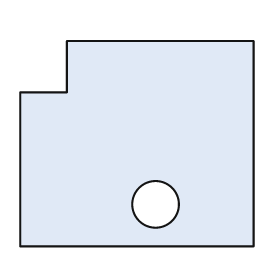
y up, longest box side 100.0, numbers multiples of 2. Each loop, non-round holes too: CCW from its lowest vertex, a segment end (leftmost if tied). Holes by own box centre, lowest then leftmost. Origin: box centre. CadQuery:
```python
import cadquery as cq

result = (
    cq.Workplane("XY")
    .moveTo(-50.0, -44.0)
    .lineTo(50.0, -44.0)
    .lineTo(50.0, 44.0)
    .lineTo(-30.0, 44.0)
    .lineTo(-30.0, 22.0)
    .lineTo(-50.0, 22.0)
    .close()
    .moveTo(8.0, -26.0)
    .circle(10.0)
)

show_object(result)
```